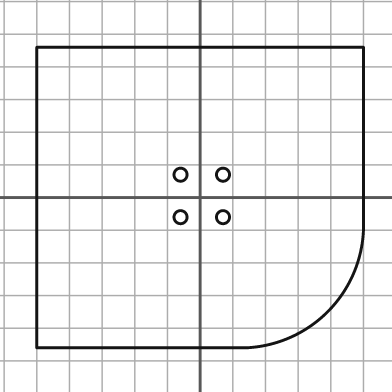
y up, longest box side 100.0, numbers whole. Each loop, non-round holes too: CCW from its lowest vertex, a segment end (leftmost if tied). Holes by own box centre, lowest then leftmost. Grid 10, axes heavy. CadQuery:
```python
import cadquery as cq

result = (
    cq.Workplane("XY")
    .moveTo(-50.0, -46.0)
    .lineTo(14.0, -46.0)
    .threePointArc((39.0, -35.0), (50.0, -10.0))
    .lineTo(50.0, 46.0)
    .lineTo(-50.0, 46.0)
    .close()
    .moveTo(-6.0, -6.0)
    .circle(2.0)
    .moveTo(7.0, -6.0)
    .circle(2.0)
    .moveTo(-6.0, 7.0)
    .circle(2.0)
    .moveTo(7.0, 7.0)
    .circle(2.0)
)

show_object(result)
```